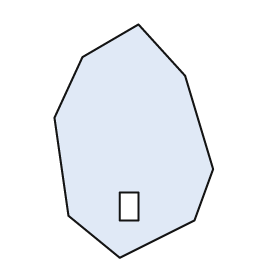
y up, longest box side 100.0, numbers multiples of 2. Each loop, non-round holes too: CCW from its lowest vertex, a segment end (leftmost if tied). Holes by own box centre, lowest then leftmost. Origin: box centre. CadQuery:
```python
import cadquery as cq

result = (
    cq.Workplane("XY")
    .moveTo(-6.0, -50.0)
    .lineTo(26.0, -34.0)
    .lineTo(34.0, -12.0)
    .lineTo(22.0, 28.0)
    .lineTo(2.0, 50.0)
    .lineTo(-22.0, 36.0)
    .lineTo(-34.0, 10.0)
    .lineTo(-28.0, -32.0)
    .close()
    .moveTo(-6.0, -34.0)
    .lineTo(2.0, -34.0)
    .lineTo(2.0, -22.0)
    .lineTo(-6.0, -22.0)
    .close()
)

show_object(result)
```